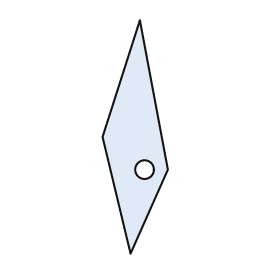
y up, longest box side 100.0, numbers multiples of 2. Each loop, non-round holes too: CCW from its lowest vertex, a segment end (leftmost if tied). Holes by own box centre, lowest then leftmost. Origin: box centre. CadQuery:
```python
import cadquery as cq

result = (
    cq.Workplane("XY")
    .moveTo(-2.0, -50.0)
    .lineTo(14.0, -14.0)
    .lineTo(2.0, 50.0)
    .lineTo(-14.0, 0.0)
    .close()
    .moveTo(4.0, -14.0)
    .circle(4.0)
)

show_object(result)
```